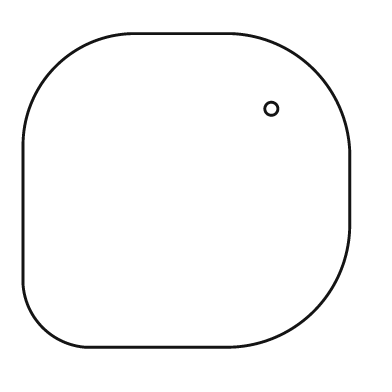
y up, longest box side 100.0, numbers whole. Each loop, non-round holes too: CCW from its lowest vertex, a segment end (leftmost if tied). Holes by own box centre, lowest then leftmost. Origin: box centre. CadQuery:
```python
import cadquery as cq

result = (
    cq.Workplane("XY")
    .moveTo(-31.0, -48.0)
    .lineTo(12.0, -48.0)
    .threePointArc((39.0, -37.0), (50.0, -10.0))
    .lineTo(50.0, 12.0)
    .threePointArc((39.0, 37.0), (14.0, 48.0))
    .lineTo(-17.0, 48.0)
    .threePointArc((-40.0, 38.0), (-50.0, 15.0))
    .lineTo(-50.0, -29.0)
    .threePointArc((-44.0, -42.0), (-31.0, -48.0))
    .close()
    .moveTo(26.0, 25.0)
    .circle(2.0)
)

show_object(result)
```